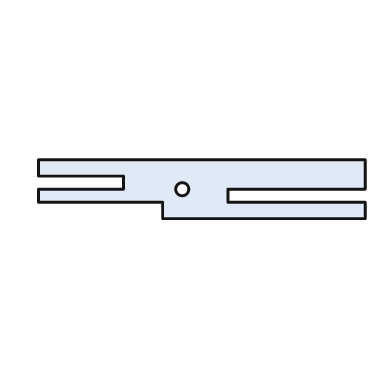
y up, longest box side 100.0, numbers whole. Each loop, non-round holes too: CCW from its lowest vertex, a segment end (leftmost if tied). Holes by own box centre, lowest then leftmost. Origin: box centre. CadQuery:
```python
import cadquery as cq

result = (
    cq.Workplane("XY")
    .moveTo(-12.0, -9.0)
    .lineTo(50.0, -9.0)
    .lineTo(50.0, -4.0)
    .lineTo(8.0, -4.0)
    .lineTo(8.0, 0.0)
    .lineTo(50.0, 0.0)
    .lineTo(50.0, 9.0)
    .lineTo(-50.0, 9.0)
    .lineTo(-50.0, 4.0)
    .lineTo(-24.0, 4.0)
    .lineTo(-24.0, 0.0)
    .lineTo(-50.0, 0.0)
    .lineTo(-50.0, -4.0)
    .lineTo(-12.0, -4.0)
    .close()
    .moveTo(-6.0, 0.0)
    .circle(2.0)
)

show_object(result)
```